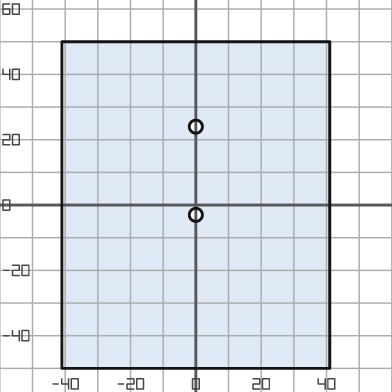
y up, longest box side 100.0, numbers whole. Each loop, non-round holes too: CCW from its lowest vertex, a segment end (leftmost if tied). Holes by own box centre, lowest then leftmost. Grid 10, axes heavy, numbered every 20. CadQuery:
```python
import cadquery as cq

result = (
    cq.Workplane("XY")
    .moveTo(-41.0, -50.0)
    .lineTo(41.0, -50.0)
    .lineTo(41.0, 50.0)
    .lineTo(-41.0, 50.0)
    .close()
    .moveTo(0.0, -3.0)
    .circle(2.0)
    .moveTo(0.0, 24.0)
    .circle(2.0)
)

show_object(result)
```